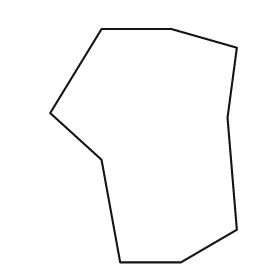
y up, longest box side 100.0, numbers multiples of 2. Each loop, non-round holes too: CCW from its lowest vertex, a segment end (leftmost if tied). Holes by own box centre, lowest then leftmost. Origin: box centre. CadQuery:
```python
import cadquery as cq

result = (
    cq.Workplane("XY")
    .moveTo(-10.0, -50.0)
    .lineTo(16.0, -50.0)
    .lineTo(40.0, -36.0)
    .lineTo(36.0, 12.0)
    .lineTo(40.0, 42.0)
    .lineTo(12.0, 50.0)
    .lineTo(-18.0, 50.0)
    .lineTo(-40.0, 14.0)
    .lineTo(-18.0, -6.0)
    .close()
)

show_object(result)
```